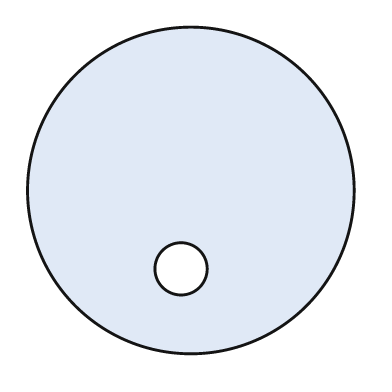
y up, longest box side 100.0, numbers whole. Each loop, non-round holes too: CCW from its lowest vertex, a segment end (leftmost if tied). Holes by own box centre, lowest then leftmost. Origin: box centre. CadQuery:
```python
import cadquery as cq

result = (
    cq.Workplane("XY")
    .moveTo(0.0, 0.0)
    .circle(50.0)
    .moveTo(-3.0, -24.0)
    .circle(8.0)
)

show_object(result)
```